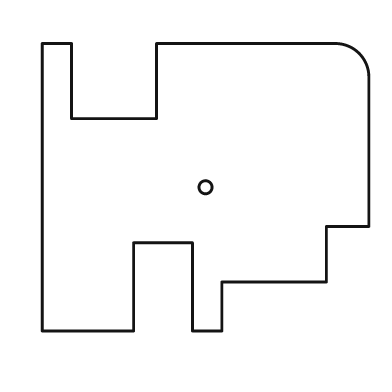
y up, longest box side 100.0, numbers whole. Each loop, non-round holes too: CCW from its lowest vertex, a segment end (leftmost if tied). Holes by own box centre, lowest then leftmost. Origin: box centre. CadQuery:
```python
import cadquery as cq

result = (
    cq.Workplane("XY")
    .moveTo(-50.0, -44.0)
    .lineTo(-22.0, -44.0)
    .lineTo(-22.0, -17.0)
    .lineTo(-4.0, -17.0)
    .lineTo(-4.0, -44.0)
    .lineTo(5.0, -44.0)
    .lineTo(5.0, -29.0)
    .lineTo(37.0, -29.0)
    .lineTo(37.0, -12.0)
    .lineTo(50.0, -12.0)
    .lineTo(50.0, 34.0)
    .threePointArc((47.0, 41.0), (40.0, 44.0))
    .lineTo(-15.0, 44.0)
    .lineTo(-15.0, 21.0)
    .lineTo(-41.0, 21.0)
    .lineTo(-41.0, 44.0)
    .lineTo(-50.0, 44.0)
    .close()
    .moveTo(0.0, 0.0)
    .circle(2.0)
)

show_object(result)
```